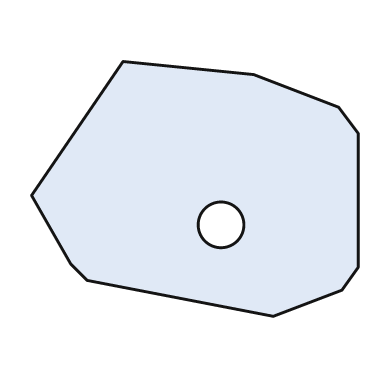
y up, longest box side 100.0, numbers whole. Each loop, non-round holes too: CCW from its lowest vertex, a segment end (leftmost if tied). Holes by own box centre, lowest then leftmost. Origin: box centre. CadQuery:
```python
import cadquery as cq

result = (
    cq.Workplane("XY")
    .moveTo(24.0, -39.0)
    .lineTo(45.0, -31.0)
    .lineTo(50.0, -24.0)
    .lineTo(50.0, 17.0)
    .lineTo(44.0, 25.0)
    .lineTo(18.0, 35.0)
    .lineTo(-22.0, 39.0)
    .lineTo(-50.0, -2.0)
    .lineTo(-38.0, -23.0)
    .lineTo(-33.0, -28.0)
    .close()
    .moveTo(8.0, -11.0)
    .circle(7.0)
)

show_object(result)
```